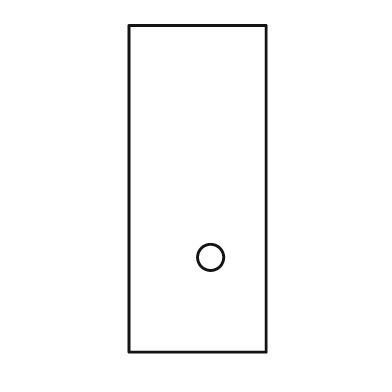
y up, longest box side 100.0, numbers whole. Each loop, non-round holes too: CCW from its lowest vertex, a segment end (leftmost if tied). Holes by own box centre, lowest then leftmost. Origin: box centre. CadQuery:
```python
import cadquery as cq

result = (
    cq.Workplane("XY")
    .moveTo(-21.0, -50.0)
    .lineTo(21.0, -50.0)
    .lineTo(21.0, 50.0)
    .lineTo(-21.0, 50.0)
    .close()
    .moveTo(4.0, -21.0)
    .circle(4.0)
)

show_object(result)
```